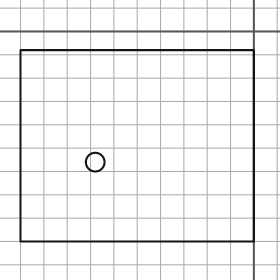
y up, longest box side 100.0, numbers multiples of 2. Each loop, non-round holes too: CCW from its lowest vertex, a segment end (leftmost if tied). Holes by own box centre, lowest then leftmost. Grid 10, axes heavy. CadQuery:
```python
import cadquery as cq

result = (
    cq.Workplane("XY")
    .moveTo(-100.0, -90.0)
    .lineTo(0.0, -90.0)
    .lineTo(0.0, -8.0)
    .lineTo(-100.0, -8.0)
    .close()
    .moveTo(-68.0, -56.0)
    .circle(4.0)
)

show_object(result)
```